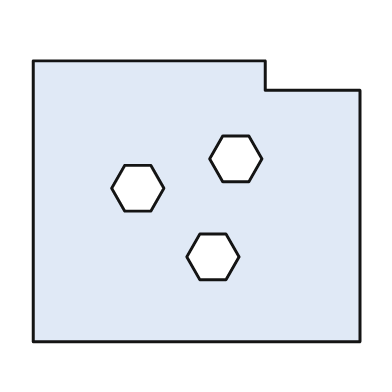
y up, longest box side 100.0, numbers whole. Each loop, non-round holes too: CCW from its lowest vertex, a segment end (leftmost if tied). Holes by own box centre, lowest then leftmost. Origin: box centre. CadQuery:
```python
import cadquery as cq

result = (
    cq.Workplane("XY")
    .moveTo(-50.0, -43.0)
    .lineTo(50.0, -43.0)
    .lineTo(50.0, 34.0)
    .lineTo(21.0, 34.0)
    .lineTo(21.0, 43.0)
    .lineTo(-50.0, 43.0)
    .close()
    .moveTo(1.0, -24.0)
    .lineTo(9.0, -24.0)
    .lineTo(13.0, -17.0)
    .lineTo(9.0, -10.0)
    .lineTo(1.0, -10.0)
    .lineTo(-3.0, -17.0)
    .close()
    .moveTo(-22.0, -3.0)
    .lineTo(-14.0, -3.0)
    .lineTo(-10.0, 4.0)
    .lineTo(-14.0, 11.0)
    .lineTo(-22.0, 11.0)
    .lineTo(-26.0, 4.0)
    .close()
    .moveTo(8.0, 6.0)
    .lineTo(16.0, 6.0)
    .lineTo(20.0, 13.0)
    .lineTo(16.0, 20.0)
    .lineTo(8.0, 20.0)
    .lineTo(4.0, 13.0)
    .close()
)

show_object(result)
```